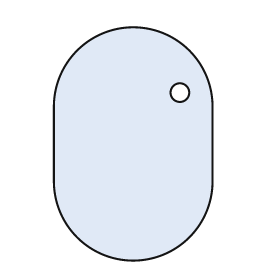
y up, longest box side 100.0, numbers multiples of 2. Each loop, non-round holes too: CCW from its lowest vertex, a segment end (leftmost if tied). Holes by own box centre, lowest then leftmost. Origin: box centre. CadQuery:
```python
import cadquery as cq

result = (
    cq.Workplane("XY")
    .moveTo(-34.0, -16.0)
    .threePointArc((0.0, -50.0), (34.0, -16.0))
    .lineTo(34.0, 16.0)
    .threePointArc((0.0, 50.0), (-34.0, 16.0))
    .close()
    .moveTo(20.0, 22.0)
    .circle(4.0)
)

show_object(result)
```